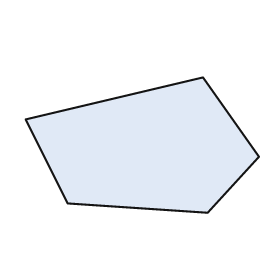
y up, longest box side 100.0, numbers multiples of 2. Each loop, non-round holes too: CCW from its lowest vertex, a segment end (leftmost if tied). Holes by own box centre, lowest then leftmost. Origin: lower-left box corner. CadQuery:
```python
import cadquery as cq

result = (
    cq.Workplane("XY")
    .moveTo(78.0, 0.0)
    .lineTo(100.0, 24.0)
    .lineTo(76.0, 58.0)
    .lineTo(0.0, 40.0)
    .lineTo(18.0, 4.0)
    .close()
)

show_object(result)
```